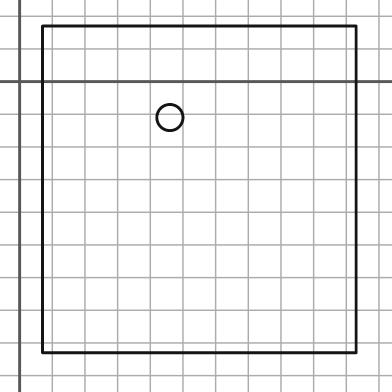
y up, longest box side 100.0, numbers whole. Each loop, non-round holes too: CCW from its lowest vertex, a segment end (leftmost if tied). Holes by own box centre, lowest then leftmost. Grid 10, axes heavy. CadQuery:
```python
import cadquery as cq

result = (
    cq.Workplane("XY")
    .moveTo(7.0, -83.0)
    .lineTo(103.0, -83.0)
    .lineTo(103.0, 17.0)
    .lineTo(7.0, 17.0)
    .close()
    .moveTo(46.0, -11.0)
    .circle(4.0)
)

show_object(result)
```